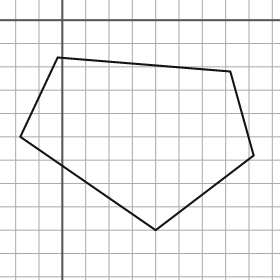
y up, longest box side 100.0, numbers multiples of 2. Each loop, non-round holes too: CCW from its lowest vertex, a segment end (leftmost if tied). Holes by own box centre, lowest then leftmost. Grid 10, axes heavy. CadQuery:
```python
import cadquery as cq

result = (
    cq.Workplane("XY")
    .moveTo(40.0, -90.0)
    .lineTo(82.0, -58.0)
    .lineTo(72.0, -22.0)
    .lineTo(-2.0, -16.0)
    .lineTo(-18.0, -50.0)
    .close()
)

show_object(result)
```